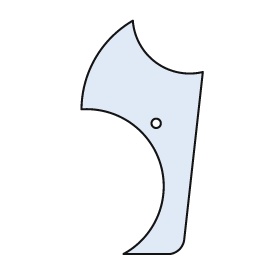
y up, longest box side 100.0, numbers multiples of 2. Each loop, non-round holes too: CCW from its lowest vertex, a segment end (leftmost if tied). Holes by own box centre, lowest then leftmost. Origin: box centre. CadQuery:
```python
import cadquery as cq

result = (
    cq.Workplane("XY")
    .moveTo(-8.0, -50.0)
    .lineTo(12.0, -50.0)
    .threePointArc((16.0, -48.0), (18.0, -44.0))
    .lineTo(26.0, 28.0)
    .threePointArc((6.0, 32.0), (-4.0, 50.0))
    .threePointArc((-20.0, 34.0), (-26.0, 12.0))
    .threePointArc((8.0, -12.0), (-8.0, -50.0))
    .close()
    .moveTo(6.0, 6.0)
    .circle(2.0)
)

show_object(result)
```